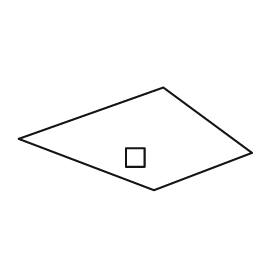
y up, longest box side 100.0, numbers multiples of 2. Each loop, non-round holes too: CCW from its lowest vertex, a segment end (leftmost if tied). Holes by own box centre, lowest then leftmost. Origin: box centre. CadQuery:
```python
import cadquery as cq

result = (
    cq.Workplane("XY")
    .moveTo(8.0, -22.0)
    .lineTo(50.0, -6.0)
    .lineTo(12.0, 22.0)
    .lineTo(-50.0, 0.0)
    .close()
    .moveTo(-4.0, -12.0)
    .lineTo(4.0, -12.0)
    .lineTo(4.0, -4.0)
    .lineTo(-4.0, -4.0)
    .close()
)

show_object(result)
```